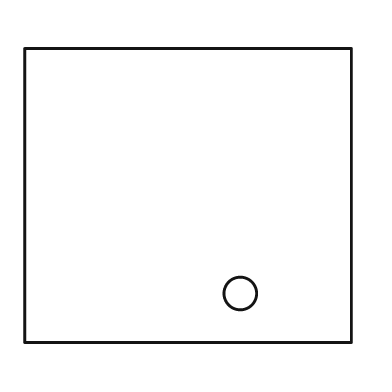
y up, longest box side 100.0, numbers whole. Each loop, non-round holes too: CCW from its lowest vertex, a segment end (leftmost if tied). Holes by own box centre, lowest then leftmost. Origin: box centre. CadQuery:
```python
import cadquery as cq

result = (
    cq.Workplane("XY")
    .moveTo(-50.0, -45.0)
    .lineTo(50.0, -45.0)
    .lineTo(50.0, 45.0)
    .lineTo(-50.0, 45.0)
    .close()
    .moveTo(16.0, -30.0)
    .circle(5.0)
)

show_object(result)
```